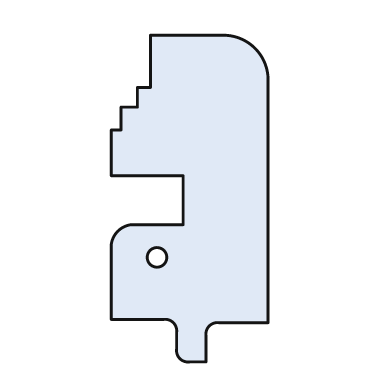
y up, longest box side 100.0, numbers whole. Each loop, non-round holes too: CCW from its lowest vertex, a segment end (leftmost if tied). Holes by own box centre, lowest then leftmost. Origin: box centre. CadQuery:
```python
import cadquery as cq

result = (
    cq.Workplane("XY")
    .moveTo(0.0, -50.0)
    .lineTo(5.0, -50.0)
    .lineTo(5.0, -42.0)
    .threePointArc((6.0, -39.0), (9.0, -38.0))
    .lineTo(24.0, -38.0)
    .lineTo(24.0, 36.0)
    .threePointArc((20.0, 46.0), (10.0, 50.0))
    .lineTo(-12.0, 50.0)
    .lineTo(-12.0, 34.0)
    .lineTo(-16.0, 34.0)
    .lineTo(-16.0, 28.0)
    .lineTo(-21.0, 28.0)
    .lineTo(-21.0, 21.0)
    .lineTo(-24.0, 21.0)
    .lineTo(-24.0, 7.0)
    .lineTo(-2.0, 7.0)
    .lineTo(-2.0, -8.0)
    .lineTo(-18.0, -8.0)
    .threePointArc((-22.0, -10.0), (-24.0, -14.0))
    .lineTo(-24.0, -37.0)
    .lineTo(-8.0, -37.0)
    .threePointArc((-5.0, -38.0), (-4.0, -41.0))
    .lineTo(-4.0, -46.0)
    .threePointArc((-3.0, -49.0), (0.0, -50.0))
    .close()
    .moveTo(-10.0, -18.0)
    .circle(3.0)
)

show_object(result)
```